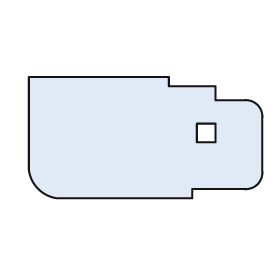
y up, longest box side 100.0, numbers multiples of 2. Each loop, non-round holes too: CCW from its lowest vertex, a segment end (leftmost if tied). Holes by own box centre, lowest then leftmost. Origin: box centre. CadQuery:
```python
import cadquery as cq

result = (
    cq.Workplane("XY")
    .moveTo(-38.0, -26.0)
    .lineTo(20.0, -26.0)
    .lineTo(20.0, -22.0)
    .lineTo(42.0, -22.0)
    .threePointArc((48.0, -20.0), (50.0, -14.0))
    .lineTo(50.0, 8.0)
    .threePointArc((48.0, 14.0), (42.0, 16.0))
    .lineTo(30.0, 16.0)
    .lineTo(30.0, 22.0)
    .lineTo(10.0, 22.0)
    .lineTo(10.0, 26.0)
    .lineTo(-50.0, 26.0)
    .lineTo(-50.0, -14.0)
    .threePointArc((-46.0, -22.0), (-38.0, -26.0))
    .close()
    .moveTo(22.0, -2.0)
    .lineTo(30.0, -2.0)
    .lineTo(30.0, 6.0)
    .lineTo(22.0, 6.0)
    .close()
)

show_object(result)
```